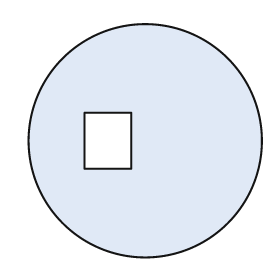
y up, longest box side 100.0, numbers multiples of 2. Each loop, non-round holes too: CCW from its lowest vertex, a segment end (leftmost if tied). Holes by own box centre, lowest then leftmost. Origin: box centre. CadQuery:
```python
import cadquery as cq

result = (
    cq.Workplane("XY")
    .moveTo(0.0, 0.0)
    .circle(50.0)
    .moveTo(-26.0, -12.0)
    .lineTo(-6.0, -12.0)
    .lineTo(-6.0, 12.0)
    .lineTo(-26.0, 12.0)
    .close()
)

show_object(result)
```